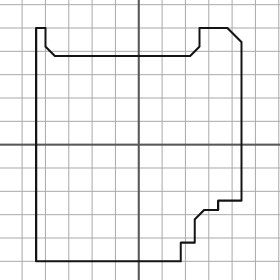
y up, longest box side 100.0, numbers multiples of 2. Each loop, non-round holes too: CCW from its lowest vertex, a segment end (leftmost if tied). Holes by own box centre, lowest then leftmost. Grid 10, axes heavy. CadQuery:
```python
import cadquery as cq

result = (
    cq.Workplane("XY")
    .moveTo(-44.0, -50.0)
    .lineTo(18.0, -50.0)
    .lineTo(18.0, -42.0)
    .lineTo(24.0, -42.0)
    .lineTo(24.0, -32.0)
    .lineTo(28.0, -28.0)
    .lineTo(34.0, -28.0)
    .lineTo(34.0, -24.0)
    .lineTo(44.0, -24.0)
    .lineTo(44.0, 44.0)
    .lineTo(38.0, 50.0)
    .lineTo(26.0, 50.0)
    .lineTo(26.0, 42.0)
    .lineTo(22.0, 38.0)
    .lineTo(-36.0, 38.0)
    .lineTo(-40.0, 42.0)
    .lineTo(-40.0, 50.0)
    .lineTo(-44.0, 50.0)
    .close()
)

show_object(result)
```